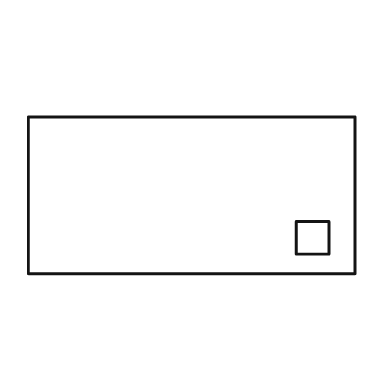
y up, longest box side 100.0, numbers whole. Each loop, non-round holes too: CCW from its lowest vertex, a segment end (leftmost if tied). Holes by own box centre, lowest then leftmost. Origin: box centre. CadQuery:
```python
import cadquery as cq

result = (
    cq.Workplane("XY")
    .moveTo(-50.0, -24.0)
    .lineTo(50.0, -24.0)
    .lineTo(50.0, 24.0)
    .lineTo(-50.0, 24.0)
    .close()
    .moveTo(32.0, -18.0)
    .lineTo(42.0, -18.0)
    .lineTo(42.0, -8.0)
    .lineTo(32.0, -8.0)
    .close()
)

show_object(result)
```